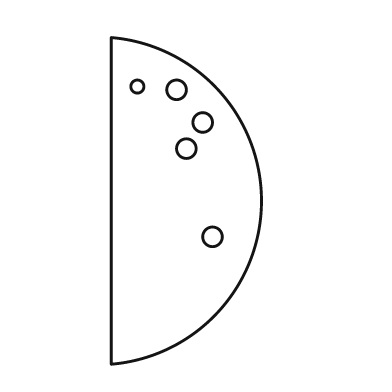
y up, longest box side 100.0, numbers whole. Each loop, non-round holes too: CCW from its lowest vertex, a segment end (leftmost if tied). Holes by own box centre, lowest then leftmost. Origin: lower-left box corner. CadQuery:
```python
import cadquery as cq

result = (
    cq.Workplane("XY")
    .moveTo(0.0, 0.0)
    .threePointArc((46.0, 50.0), (0.0, 100.0))
    .close()
    .moveTo(31.0, 39.0)
    .circle(3.0)
    .moveTo(23.0, 66.0)
    .circle(3.0)
    .moveTo(28.0, 74.0)
    .circle(3.0)
    .moveTo(20.0, 84.0)
    .circle(3.0)
    .moveTo(8.0, 85.0)
    .circle(2.0)
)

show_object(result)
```